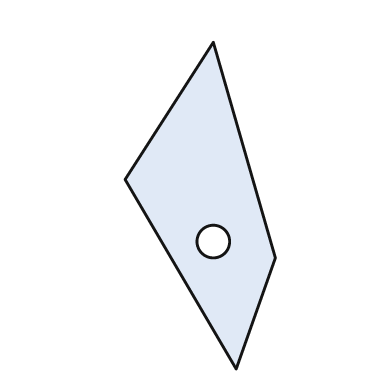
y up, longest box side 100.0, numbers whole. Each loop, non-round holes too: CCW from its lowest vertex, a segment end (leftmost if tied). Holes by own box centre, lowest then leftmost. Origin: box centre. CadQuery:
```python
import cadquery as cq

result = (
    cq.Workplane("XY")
    .moveTo(11.0, -50.0)
    .lineTo(23.0, -16.0)
    .lineTo(4.0, 50.0)
    .lineTo(-23.0, 8.0)
    .close()
    .moveTo(4.0, -11.0)
    .circle(5.0)
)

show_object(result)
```